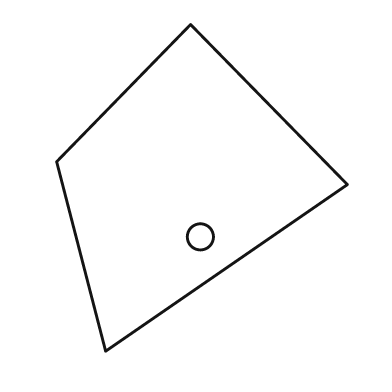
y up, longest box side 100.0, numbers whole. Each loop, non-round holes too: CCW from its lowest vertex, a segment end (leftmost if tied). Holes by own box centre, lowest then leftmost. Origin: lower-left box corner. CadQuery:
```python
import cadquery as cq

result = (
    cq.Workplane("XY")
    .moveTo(15.0, 0.0)
    .lineTo(89.0, 51.0)
    .lineTo(41.0, 100.0)
    .lineTo(0.0, 58.0)
    .close()
    .moveTo(44.0, 35.0)
    .circle(4.0)
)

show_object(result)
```